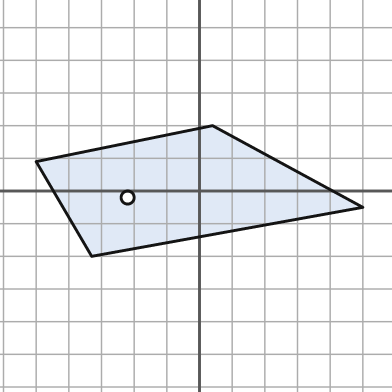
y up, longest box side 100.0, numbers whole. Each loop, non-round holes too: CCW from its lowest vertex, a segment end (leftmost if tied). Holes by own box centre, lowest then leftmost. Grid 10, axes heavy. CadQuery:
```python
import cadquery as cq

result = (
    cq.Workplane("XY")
    .moveTo(-33.0, -20.0)
    .lineTo(50.0, -5.0)
    .lineTo(4.0, 20.0)
    .lineTo(-50.0, 9.0)
    .close()
    .moveTo(-22.0, -2.0)
    .circle(2.0)
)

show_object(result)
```